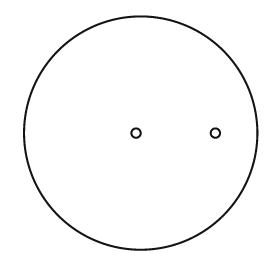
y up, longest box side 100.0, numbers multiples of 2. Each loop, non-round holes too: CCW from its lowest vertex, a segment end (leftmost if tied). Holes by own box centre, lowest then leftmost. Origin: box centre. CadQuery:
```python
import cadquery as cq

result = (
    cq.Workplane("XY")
    .moveTo(0.0, 0.0)
    .circle(50.0)
    .moveTo(-2.0, 0.0)
    .circle(2.0)
    .moveTo(32.0, 0.0)
    .circle(2.0)
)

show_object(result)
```